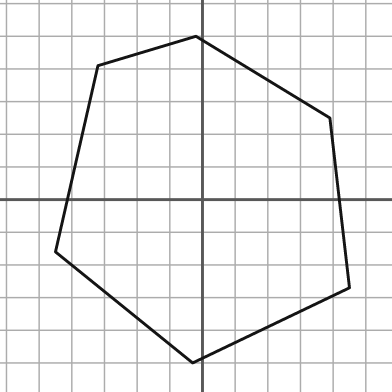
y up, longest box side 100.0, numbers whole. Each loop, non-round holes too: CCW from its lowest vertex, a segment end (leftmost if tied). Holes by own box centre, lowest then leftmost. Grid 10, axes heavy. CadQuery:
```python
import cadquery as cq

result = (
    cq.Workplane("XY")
    .moveTo(-3.0, -50.0)
    .lineTo(45.0, -27.0)
    .lineTo(39.0, 25.0)
    .lineTo(-2.0, 50.0)
    .lineTo(-32.0, 41.0)
    .lineTo(-45.0, -16.0)
    .close()
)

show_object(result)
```